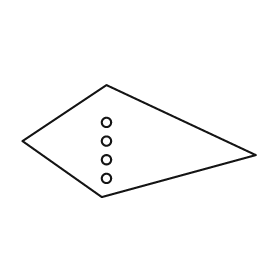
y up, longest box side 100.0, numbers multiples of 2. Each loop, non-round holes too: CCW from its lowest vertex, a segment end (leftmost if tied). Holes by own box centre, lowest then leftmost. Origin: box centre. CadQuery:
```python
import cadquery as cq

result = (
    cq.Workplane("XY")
    .moveTo(-16.0, -24.0)
    .lineTo(50.0, -6.0)
    .lineTo(-14.0, 24.0)
    .lineTo(-50.0, 0.0)
    .close()
    .moveTo(-14.0, -16.0)
    .circle(2.0)
    .moveTo(-14.0, -8.0)
    .circle(2.0)
    .moveTo(-14.0, 0.0)
    .circle(2.0)
    .moveTo(-14.0, 8.0)
    .circle(2.0)
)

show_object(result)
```